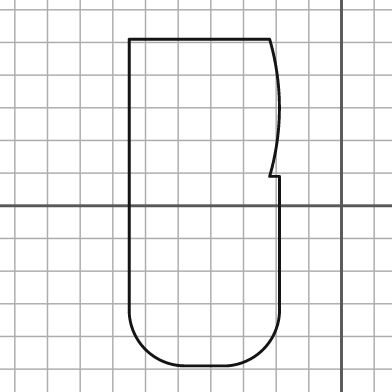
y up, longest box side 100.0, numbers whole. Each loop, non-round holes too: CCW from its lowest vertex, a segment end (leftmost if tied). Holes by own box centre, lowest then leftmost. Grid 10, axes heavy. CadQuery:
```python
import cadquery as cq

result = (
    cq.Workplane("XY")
    .moveTo(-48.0, -49.0)
    .lineTo(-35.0, -49.0)
    .threePointArc((-24.0, -44.0), (-19.0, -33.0))
    .lineTo(-19.0, 9.0)
    .lineTo(-22.0, 9.0)
    .threePointArc((-19.0, 30.0), (-22.0, 51.0))
    .lineTo(-65.0, 51.0)
    .lineTo(-65.0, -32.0)
    .threePointArc((-60.0, -44.0), (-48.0, -49.0))
    .close()
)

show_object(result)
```